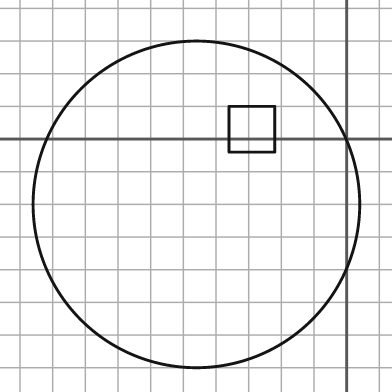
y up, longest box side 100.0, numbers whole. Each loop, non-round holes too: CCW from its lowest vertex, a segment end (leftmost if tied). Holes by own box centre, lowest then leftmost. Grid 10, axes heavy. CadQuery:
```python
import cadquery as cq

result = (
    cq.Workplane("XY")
    .moveTo(-46.0, -20.0)
    .circle(50.0)
    .moveTo(-36.0, -4.0)
    .lineTo(-22.0, -4.0)
    .lineTo(-22.0, 10.0)
    .lineTo(-36.0, 10.0)
    .close()
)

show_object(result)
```